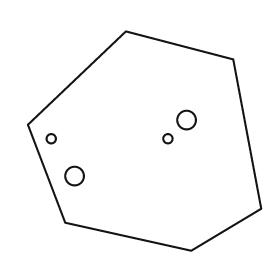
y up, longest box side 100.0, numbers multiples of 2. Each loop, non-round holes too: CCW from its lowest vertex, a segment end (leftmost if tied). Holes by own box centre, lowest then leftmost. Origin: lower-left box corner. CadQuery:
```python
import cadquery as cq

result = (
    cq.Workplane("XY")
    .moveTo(70.0, 0.0)
    .lineTo(100.0, 18.0)
    .lineTo(88.0, 82.0)
    .lineTo(42.0, 94.0)
    .lineTo(0.0, 54.0)
    .lineTo(16.0, 12.0)
    .close()
    .moveTo(20.0, 32.0)
    .circle(4.0)
    .moveTo(10.0, 48.0)
    .circle(2.0)
    .moveTo(60.0, 48.0)
    .circle(2.0)
    .moveTo(68.0, 56.0)
    .circle(4.0)
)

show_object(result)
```